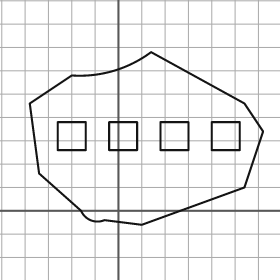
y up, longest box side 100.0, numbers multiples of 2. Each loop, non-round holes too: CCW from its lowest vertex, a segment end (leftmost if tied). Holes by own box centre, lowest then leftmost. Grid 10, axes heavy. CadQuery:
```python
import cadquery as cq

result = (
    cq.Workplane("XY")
    .moveTo(10.0, -6.0)
    .lineTo(54.0, 10.0)
    .lineTo(62.0, 34.0)
    .lineTo(54.0, 46.0)
    .lineTo(14.0, 68.0)
    .threePointArc((-2.0, 60.0), (-20.0, 58.0))
    .lineTo(-38.0, 46.0)
    .lineTo(-34.0, 16.0)
    .lineTo(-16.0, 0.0)
    .threePointArc((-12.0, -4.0), (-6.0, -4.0))
    .close()
    .moveTo(-26.0, 26.0)
    .lineTo(-14.0, 26.0)
    .lineTo(-14.0, 38.0)
    .lineTo(-26.0, 38.0)
    .close()
    .moveTo(-4.0, 26.0)
    .lineTo(8.0, 26.0)
    .lineTo(8.0, 38.0)
    .lineTo(-4.0, 38.0)
    .close()
    .moveTo(18.0, 26.0)
    .lineTo(30.0, 26.0)
    .lineTo(30.0, 38.0)
    .lineTo(18.0, 38.0)
    .close()
    .moveTo(40.0, 26.0)
    .lineTo(52.0, 26.0)
    .lineTo(52.0, 38.0)
    .lineTo(40.0, 38.0)
    .close()
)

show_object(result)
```